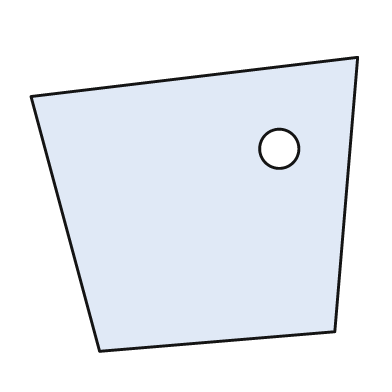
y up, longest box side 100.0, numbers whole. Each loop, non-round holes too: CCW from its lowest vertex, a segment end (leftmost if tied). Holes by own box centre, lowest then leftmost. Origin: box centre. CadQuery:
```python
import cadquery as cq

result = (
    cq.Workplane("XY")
    .moveTo(-29.0, -45.0)
    .lineTo(43.0, -39.0)
    .lineTo(50.0, 45.0)
    .lineTo(-50.0, 33.0)
    .close()
    .moveTo(26.0, 17.0)
    .circle(6.0)
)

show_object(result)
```